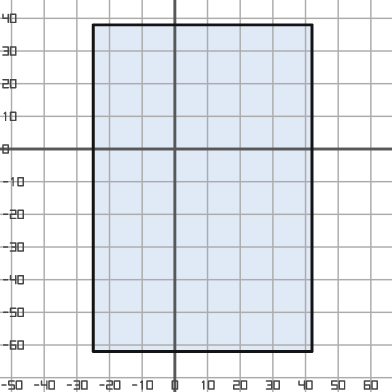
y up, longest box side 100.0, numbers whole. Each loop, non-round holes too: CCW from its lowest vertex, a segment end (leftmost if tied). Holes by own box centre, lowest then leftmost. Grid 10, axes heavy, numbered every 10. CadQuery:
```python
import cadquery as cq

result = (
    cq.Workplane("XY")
    .moveTo(-25.0, -62.0)
    .lineTo(42.0, -62.0)
    .lineTo(42.0, 38.0)
    .lineTo(-25.0, 38.0)
    .close()
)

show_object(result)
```